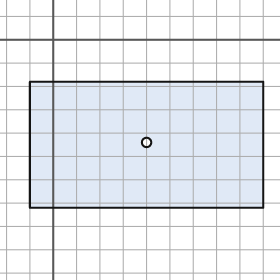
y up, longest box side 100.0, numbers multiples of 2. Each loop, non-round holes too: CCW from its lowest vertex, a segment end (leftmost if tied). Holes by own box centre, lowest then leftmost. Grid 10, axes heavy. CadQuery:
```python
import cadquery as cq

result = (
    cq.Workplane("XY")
    .moveTo(-10.0, -72.0)
    .lineTo(90.0, -72.0)
    .lineTo(90.0, -18.0)
    .lineTo(-10.0, -18.0)
    .close()
    .moveTo(40.0, -44.0)
    .circle(2.0)
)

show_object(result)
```